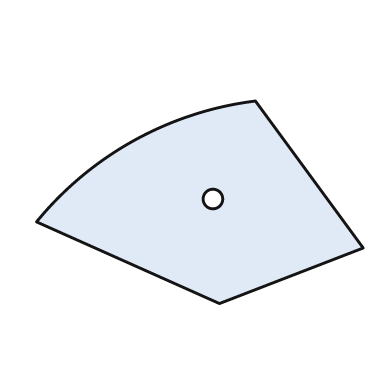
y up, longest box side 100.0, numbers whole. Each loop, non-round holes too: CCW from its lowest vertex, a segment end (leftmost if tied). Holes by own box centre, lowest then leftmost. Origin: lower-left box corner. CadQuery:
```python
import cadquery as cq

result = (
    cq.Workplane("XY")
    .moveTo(56.0, 0.0)
    .lineTo(100.0, 17.0)
    .lineTo(67.0, 62.0)
    .threePointArc((30.0, 50.0), (0.0, 25.0))
    .close()
    .moveTo(54.0, 32.0)
    .circle(3.0)
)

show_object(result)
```